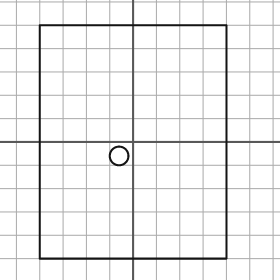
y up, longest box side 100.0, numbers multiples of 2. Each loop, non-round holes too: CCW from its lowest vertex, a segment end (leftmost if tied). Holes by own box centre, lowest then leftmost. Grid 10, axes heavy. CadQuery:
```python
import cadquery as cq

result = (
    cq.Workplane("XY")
    .moveTo(-40.0, -50.0)
    .lineTo(40.0, -50.0)
    .lineTo(40.0, 50.0)
    .lineTo(-40.0, 50.0)
    .close()
    .moveTo(-6.0, -6.0)
    .circle(4.0)
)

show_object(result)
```